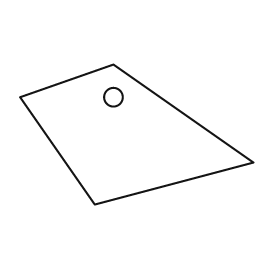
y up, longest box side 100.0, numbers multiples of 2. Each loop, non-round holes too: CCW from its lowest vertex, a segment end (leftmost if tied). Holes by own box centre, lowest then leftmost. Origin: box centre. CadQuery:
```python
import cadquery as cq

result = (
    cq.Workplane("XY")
    .moveTo(-18.0, -30.0)
    .lineTo(50.0, -12.0)
    .lineTo(-10.0, 30.0)
    .lineTo(-50.0, 16.0)
    .close()
    .moveTo(-10.0, 16.0)
    .circle(4.0)
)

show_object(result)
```